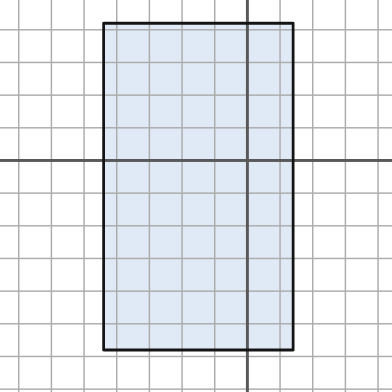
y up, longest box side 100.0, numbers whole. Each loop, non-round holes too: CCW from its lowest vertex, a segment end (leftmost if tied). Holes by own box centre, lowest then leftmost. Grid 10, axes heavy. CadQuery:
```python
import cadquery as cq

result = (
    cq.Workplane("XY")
    .moveTo(-44.0, -58.0)
    .lineTo(14.0, -58.0)
    .lineTo(14.0, 42.0)
    .lineTo(-44.0, 42.0)
    .close()
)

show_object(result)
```